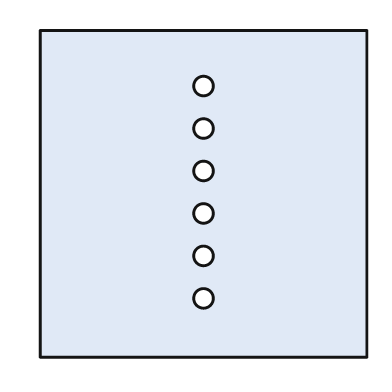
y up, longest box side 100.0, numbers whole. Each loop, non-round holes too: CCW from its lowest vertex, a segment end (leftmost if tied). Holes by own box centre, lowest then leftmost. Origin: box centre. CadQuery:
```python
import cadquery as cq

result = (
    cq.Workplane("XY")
    .moveTo(-50.0, -50.0)
    .lineTo(50.0, -50.0)
    .lineTo(50.0, 50.0)
    .lineTo(-50.0, 50.0)
    .close()
    .moveTo(0.0, -32.0)
    .circle(3.0)
    .moveTo(0.0, -19.0)
    .circle(3.0)
    .moveTo(0.0, -6.0)
    .circle(3.0)
    .moveTo(0.0, 7.0)
    .circle(3.0)
    .moveTo(0.0, 20.0)
    .circle(3.0)
    .moveTo(0.0, 33.0)
    .circle(3.0)
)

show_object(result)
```